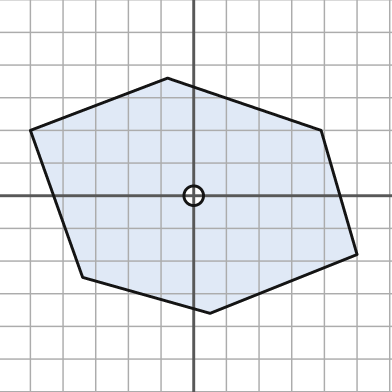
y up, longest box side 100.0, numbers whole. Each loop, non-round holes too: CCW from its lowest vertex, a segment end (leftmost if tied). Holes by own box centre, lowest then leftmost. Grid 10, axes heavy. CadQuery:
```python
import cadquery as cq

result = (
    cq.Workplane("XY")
    .moveTo(5.0, -36.0)
    .lineTo(50.0, -18.0)
    .lineTo(39.0, 20.0)
    .lineTo(-8.0, 36.0)
    .lineTo(-50.0, 20.0)
    .lineTo(-34.0, -25.0)
    .close()
    .moveTo(0.0, 0.0)
    .circle(3.0)
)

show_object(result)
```